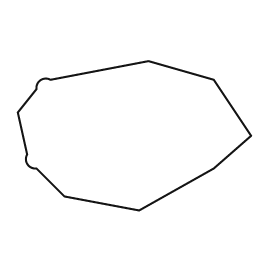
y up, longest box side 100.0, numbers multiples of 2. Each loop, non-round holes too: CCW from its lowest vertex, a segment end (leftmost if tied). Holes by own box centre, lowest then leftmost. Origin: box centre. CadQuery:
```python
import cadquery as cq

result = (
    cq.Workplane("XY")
    .moveTo(2.0, -32.0)
    .lineTo(34.0, -14.0)
    .lineTo(50.0, 0.0)
    .lineTo(34.0, 24.0)
    .lineTo(6.0, 32.0)
    .lineTo(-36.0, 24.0)
    .threePointArc((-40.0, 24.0), (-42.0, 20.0))
    .lineTo(-50.0, 10.0)
    .lineTo(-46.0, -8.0)
    .threePointArc((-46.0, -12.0), (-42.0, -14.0))
    .lineTo(-30.0, -26.0)
    .close()
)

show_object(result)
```